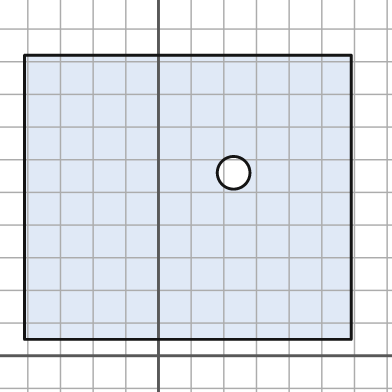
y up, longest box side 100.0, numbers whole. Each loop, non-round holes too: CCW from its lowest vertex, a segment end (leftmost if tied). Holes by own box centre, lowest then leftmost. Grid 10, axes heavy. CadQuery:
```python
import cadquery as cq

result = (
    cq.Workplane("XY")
    .moveTo(-41.0, 5.0)
    .lineTo(59.0, 5.0)
    .lineTo(59.0, 92.0)
    .lineTo(-41.0, 92.0)
    .close()
    .moveTo(23.0, 56.0)
    .circle(5.0)
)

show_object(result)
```